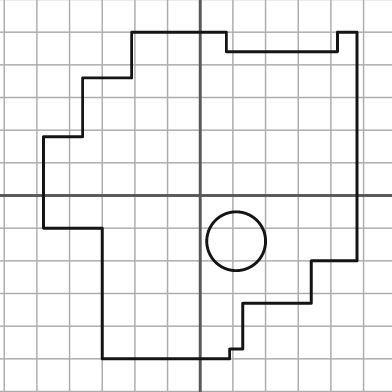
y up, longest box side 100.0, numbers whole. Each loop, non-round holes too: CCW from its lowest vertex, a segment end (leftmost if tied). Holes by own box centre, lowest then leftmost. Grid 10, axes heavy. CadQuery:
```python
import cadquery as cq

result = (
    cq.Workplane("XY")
    .moveTo(-30.0, -50.0)
    .lineTo(9.0, -50.0)
    .lineTo(9.0, -47.0)
    .lineTo(13.0, -47.0)
    .lineTo(13.0, -33.0)
    .lineTo(34.0, -33.0)
    .lineTo(34.0, -20.0)
    .lineTo(48.0, -20.0)
    .lineTo(48.0, 50.0)
    .lineTo(42.0, 50.0)
    .lineTo(42.0, 44.0)
    .lineTo(8.0, 44.0)
    .lineTo(8.0, 50.0)
    .lineTo(-21.0, 50.0)
    .lineTo(-21.0, 36.0)
    .lineTo(-36.0, 36.0)
    .lineTo(-36.0, 18.0)
    .lineTo(-48.0, 18.0)
    .lineTo(-48.0, -10.0)
    .lineTo(-30.0, -10.0)
    .close()
    .moveTo(11.0, -14.0)
    .circle(9.0)
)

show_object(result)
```